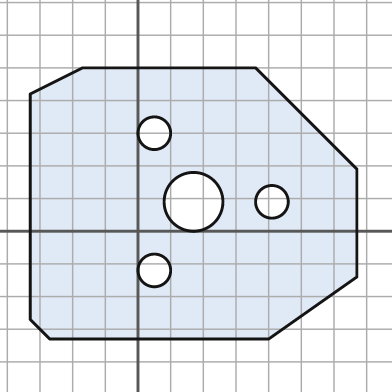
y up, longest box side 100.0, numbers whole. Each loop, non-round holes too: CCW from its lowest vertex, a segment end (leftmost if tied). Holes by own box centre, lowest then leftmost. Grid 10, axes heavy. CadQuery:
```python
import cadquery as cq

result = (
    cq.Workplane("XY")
    .moveTo(-27.0, -33.0)
    .lineTo(40.0, -33.0)
    .lineTo(67.0, -14.0)
    .lineTo(67.0, 19.0)
    .lineTo(36.0, 50.0)
    .lineTo(-17.0, 50.0)
    .lineTo(-33.0, 42.0)
    .lineTo(-33.0, -27.0)
    .close()
    .moveTo(5.0, -12.0)
    .circle(5.0)
    .moveTo(17.0, 9.0)
    .circle(9.0)
    .moveTo(41.0, 9.0)
    .circle(5.0)
    .moveTo(5.0, 30.0)
    .circle(5.0)
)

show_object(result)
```